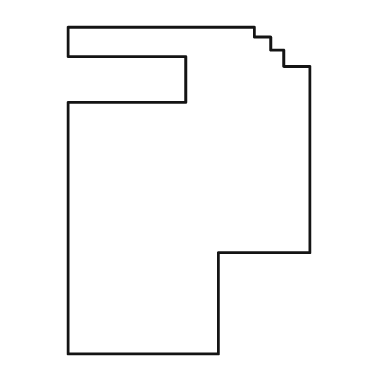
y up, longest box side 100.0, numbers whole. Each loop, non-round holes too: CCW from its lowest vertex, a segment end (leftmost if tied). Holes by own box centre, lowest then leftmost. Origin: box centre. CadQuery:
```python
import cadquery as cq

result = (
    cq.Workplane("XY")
    .moveTo(-37.0, -50.0)
    .lineTo(9.0, -50.0)
    .lineTo(9.0, -19.0)
    .lineTo(37.0, -19.0)
    .lineTo(37.0, 38.0)
    .lineTo(29.0, 38.0)
    .lineTo(29.0, 43.0)
    .lineTo(25.0, 43.0)
    .lineTo(25.0, 47.0)
    .lineTo(20.0, 47.0)
    .lineTo(20.0, 50.0)
    .lineTo(-37.0, 50.0)
    .lineTo(-37.0, 41.0)
    .lineTo(-1.0, 41.0)
    .lineTo(-1.0, 27.0)
    .lineTo(-37.0, 27.0)
    .close()
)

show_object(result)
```